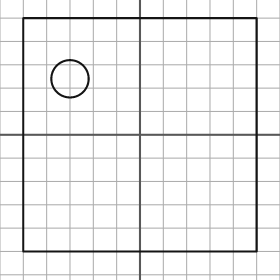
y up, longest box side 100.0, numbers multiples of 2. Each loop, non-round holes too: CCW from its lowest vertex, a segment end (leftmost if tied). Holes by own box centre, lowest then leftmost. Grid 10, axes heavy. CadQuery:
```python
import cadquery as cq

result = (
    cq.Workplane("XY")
    .moveTo(-50.0, -50.0)
    .lineTo(50.0, -50.0)
    .lineTo(50.0, 50.0)
    .lineTo(-50.0, 50.0)
    .close()
    .moveTo(-30.0, 24.0)
    .circle(8.0)
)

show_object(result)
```